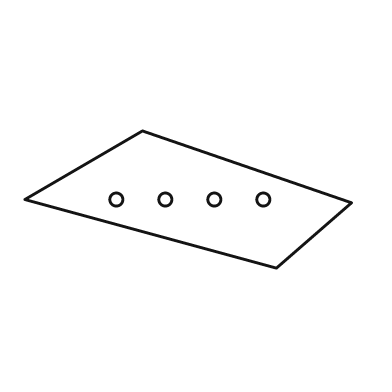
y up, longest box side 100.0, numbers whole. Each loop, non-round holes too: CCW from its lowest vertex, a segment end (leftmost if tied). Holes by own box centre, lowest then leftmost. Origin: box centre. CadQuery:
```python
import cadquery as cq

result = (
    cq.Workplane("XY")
    .moveTo(27.0, -21.0)
    .lineTo(50.0, -1.0)
    .lineTo(-14.0, 21.0)
    .lineTo(-50.0, 0.0)
    .close()
    .moveTo(-22.0, 0.0)
    .circle(2.0)
    .moveTo(-7.0, 0.0)
    .circle(2.0)
    .moveTo(8.0, 0.0)
    .circle(2.0)
    .moveTo(23.0, 0.0)
    .circle(2.0)
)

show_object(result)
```